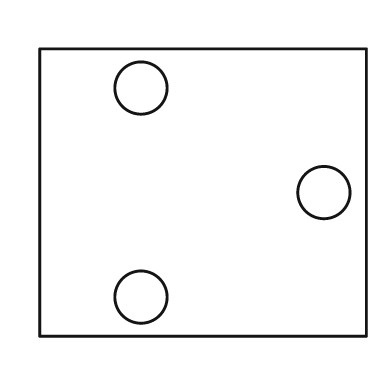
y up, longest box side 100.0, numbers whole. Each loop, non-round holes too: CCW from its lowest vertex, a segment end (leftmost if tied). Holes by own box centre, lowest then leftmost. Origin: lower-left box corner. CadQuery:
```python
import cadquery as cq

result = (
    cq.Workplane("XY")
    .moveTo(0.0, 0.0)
    .lineTo(100.0, 0.0)
    .lineTo(100.0, 88.0)
    .lineTo(0.0, 88.0)
    .close()
    .moveTo(31.0, 12.0)
    .circle(8.0)
    .moveTo(87.0, 44.0)
    .circle(8.0)
    .moveTo(31.0, 76.0)
    .circle(8.0)
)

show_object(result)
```